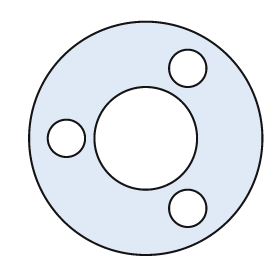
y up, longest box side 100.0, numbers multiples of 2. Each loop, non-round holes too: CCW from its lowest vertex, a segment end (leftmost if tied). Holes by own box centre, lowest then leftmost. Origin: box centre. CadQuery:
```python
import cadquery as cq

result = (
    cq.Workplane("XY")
    .moveTo(0.0, 0.0)
    .circle(50.0)
    .moveTo(18.0, -30.0)
    .circle(8.0)
    .moveTo(-34.0, 0.0)
    .circle(8.0)
    .moveTo(0.0, 0.0)
    .circle(22.0)
    .moveTo(18.0, 30.0)
    .circle(8.0)
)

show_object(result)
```